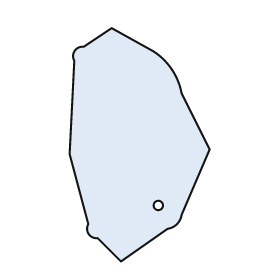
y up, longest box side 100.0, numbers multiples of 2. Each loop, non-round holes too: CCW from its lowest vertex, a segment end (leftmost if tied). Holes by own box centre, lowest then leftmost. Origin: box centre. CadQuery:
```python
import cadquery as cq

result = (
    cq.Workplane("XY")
    .moveTo(-8.0, -50.0)
    .lineTo(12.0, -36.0)
    .threePointArc((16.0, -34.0), (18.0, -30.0))
    .lineTo(30.0, -2.0)
    .lineTo(18.0, 22.0)
    .threePointArc((14.0, 32.0), (6.0, 40.0))
    .lineTo(-12.0, 50.0)
    .lineTo(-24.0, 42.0)
    .threePointArc((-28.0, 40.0), (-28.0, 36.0))
    .lineTo(-30.0, -4.0)
    .lineTo(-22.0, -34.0)
    .threePointArc((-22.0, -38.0), (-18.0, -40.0))
    .close()
    .moveTo(8.0, -26.0)
    .circle(2.0)
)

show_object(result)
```